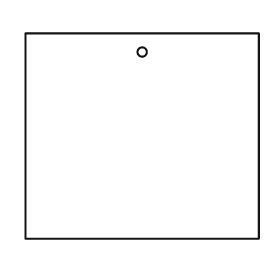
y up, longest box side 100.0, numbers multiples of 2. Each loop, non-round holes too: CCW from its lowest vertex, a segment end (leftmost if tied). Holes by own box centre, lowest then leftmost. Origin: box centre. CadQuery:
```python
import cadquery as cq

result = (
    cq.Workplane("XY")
    .moveTo(-50.0, -44.0)
    .lineTo(50.0, -44.0)
    .lineTo(50.0, 44.0)
    .lineTo(-50.0, 44.0)
    .close()
    .moveTo(0.0, 36.0)
    .circle(2.0)
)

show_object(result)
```